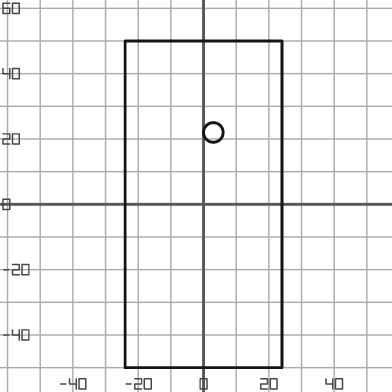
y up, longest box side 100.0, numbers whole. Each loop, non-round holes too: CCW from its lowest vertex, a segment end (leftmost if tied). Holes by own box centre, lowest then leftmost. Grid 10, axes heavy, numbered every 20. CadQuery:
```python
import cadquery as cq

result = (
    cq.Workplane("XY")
    .moveTo(-24.0, -50.0)
    .lineTo(24.0, -50.0)
    .lineTo(24.0, 50.0)
    .lineTo(-24.0, 50.0)
    .close()
    .moveTo(3.0, 22.0)
    .circle(3.0)
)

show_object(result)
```